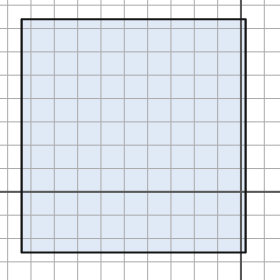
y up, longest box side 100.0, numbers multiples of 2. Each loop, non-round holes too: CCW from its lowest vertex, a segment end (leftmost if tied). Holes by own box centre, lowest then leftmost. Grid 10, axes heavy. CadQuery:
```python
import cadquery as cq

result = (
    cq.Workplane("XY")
    .moveTo(-94.0, -26.0)
    .lineTo(2.0, -26.0)
    .lineTo(2.0, 74.0)
    .lineTo(-94.0, 74.0)
    .close()
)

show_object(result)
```